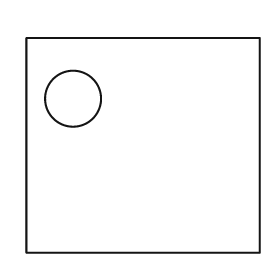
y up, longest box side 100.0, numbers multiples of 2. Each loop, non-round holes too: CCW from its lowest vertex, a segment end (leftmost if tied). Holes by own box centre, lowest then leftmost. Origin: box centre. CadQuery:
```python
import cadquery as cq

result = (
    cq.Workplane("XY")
    .moveTo(-50.0, -46.0)
    .lineTo(50.0, -46.0)
    .lineTo(50.0, 46.0)
    .lineTo(-50.0, 46.0)
    .close()
    .moveTo(-30.0, 20.0)
    .circle(12.0)
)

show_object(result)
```